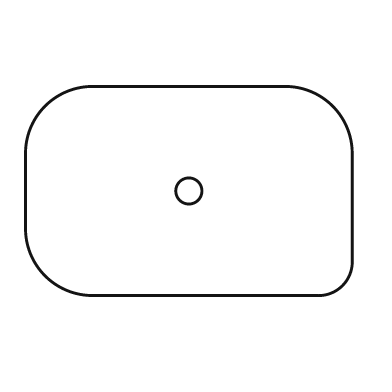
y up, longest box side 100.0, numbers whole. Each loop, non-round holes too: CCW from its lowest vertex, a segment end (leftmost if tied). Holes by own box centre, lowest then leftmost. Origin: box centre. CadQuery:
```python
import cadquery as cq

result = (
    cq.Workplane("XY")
    .moveTo(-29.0, -32.0)
    .lineTo(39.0, -32.0)
    .threePointArc((47.0, -29.0), (50.0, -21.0))
    .lineTo(50.0, 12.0)
    .threePointArc((44.0, 26.0), (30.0, 32.0))
    .lineTo(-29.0, 32.0)
    .threePointArc((-44.0, 26.0), (-50.0, 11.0))
    .lineTo(-50.0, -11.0)
    .threePointArc((-44.0, -26.0), (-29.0, -32.0))
    .close()
    .moveTo(0.0, 0.0)
    .circle(4.0)
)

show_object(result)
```